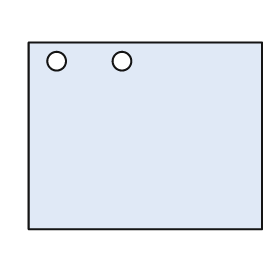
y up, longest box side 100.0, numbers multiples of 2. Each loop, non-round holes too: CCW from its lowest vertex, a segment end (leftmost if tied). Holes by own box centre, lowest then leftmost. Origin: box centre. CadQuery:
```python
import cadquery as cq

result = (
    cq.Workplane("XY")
    .moveTo(-50.0, -40.0)
    .lineTo(50.0, -40.0)
    .lineTo(50.0, 40.0)
    .lineTo(-50.0, 40.0)
    .close()
    .moveTo(-38.0, 32.0)
    .circle(4.0)
    .moveTo(-10.0, 32.0)
    .circle(4.0)
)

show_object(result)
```